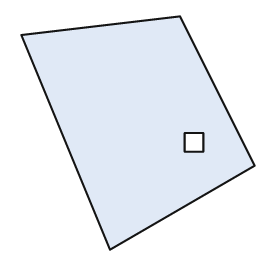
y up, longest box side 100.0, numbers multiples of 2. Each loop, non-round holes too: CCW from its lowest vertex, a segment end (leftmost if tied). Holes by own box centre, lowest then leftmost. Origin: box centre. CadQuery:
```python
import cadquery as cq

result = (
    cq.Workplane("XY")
    .moveTo(-12.0, -50.0)
    .lineTo(50.0, -14.0)
    .lineTo(18.0, 50.0)
    .lineTo(-50.0, 42.0)
    .close()
    .moveTo(20.0, -8.0)
    .lineTo(28.0, -8.0)
    .lineTo(28.0, 0.0)
    .lineTo(20.0, 0.0)
    .close()
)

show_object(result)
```